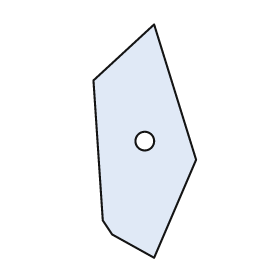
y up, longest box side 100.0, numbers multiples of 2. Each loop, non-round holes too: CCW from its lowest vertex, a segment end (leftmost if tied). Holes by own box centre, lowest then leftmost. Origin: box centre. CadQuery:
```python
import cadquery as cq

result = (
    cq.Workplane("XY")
    .moveTo(4.0, -50.0)
    .lineTo(22.0, -8.0)
    .lineTo(4.0, 50.0)
    .lineTo(-22.0, 26.0)
    .lineTo(-18.0, -34.0)
    .lineTo(-14.0, -40.0)
    .close()
    .moveTo(0.0, 0.0)
    .circle(4.0)
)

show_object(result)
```